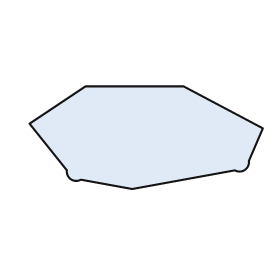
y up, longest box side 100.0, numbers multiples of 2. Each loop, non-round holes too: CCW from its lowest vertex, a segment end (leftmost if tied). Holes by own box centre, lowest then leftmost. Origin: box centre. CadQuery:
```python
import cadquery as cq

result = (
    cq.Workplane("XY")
    .moveTo(-6.0, -22.0)
    .lineTo(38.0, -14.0)
    .threePointArc((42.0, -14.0), (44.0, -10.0))
    .lineTo(50.0, 4.0)
    .lineTo(16.0, 22.0)
    .lineTo(-26.0, 22.0)
    .lineTo(-50.0, 6.0)
    .lineTo(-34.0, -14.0)
    .threePointArc((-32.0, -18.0), (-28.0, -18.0))
    .close()
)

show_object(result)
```